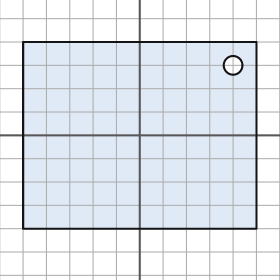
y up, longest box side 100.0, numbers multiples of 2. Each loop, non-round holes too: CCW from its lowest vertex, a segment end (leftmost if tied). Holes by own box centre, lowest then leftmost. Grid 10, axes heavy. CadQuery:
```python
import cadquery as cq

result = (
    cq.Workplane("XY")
    .moveTo(-50.0, -40.0)
    .lineTo(50.0, -40.0)
    .lineTo(50.0, 40.0)
    .lineTo(-50.0, 40.0)
    .close()
    .moveTo(40.0, 30.0)
    .circle(4.0)
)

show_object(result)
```